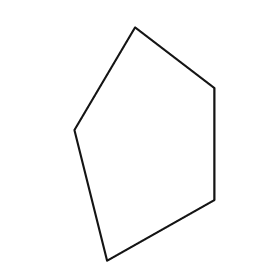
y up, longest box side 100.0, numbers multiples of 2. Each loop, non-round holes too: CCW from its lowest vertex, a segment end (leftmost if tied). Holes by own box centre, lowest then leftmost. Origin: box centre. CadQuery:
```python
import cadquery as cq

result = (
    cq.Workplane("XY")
    .moveTo(-16.0, -50.0)
    .lineTo(30.0, -24.0)
    .lineTo(30.0, 24.0)
    .lineTo(-4.0, 50.0)
    .lineTo(-30.0, 6.0)
    .close()
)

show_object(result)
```